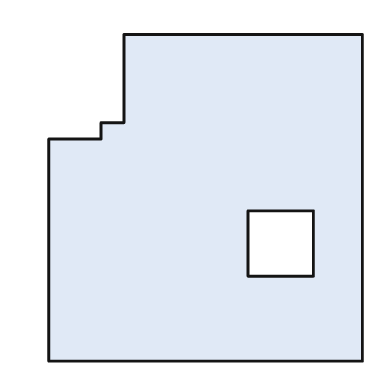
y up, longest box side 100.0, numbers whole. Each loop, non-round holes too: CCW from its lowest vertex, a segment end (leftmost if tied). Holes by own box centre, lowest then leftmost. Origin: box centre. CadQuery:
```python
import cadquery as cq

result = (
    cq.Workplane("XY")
    .moveTo(-48.0, -50.0)
    .lineTo(48.0, -50.0)
    .lineTo(48.0, 50.0)
    .lineTo(-25.0, 50.0)
    .lineTo(-25.0, 23.0)
    .lineTo(-32.0, 23.0)
    .lineTo(-32.0, 18.0)
    .lineTo(-48.0, 18.0)
    .close()
    .moveTo(13.0, -24.0)
    .lineTo(33.0, -24.0)
    .lineTo(33.0, -4.0)
    .lineTo(13.0, -4.0)
    .close()
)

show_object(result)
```